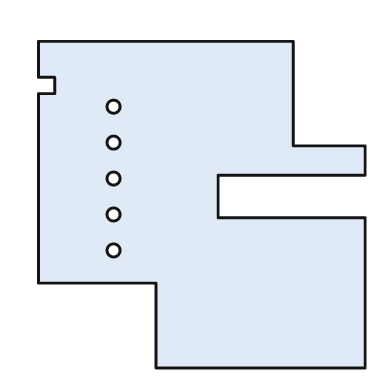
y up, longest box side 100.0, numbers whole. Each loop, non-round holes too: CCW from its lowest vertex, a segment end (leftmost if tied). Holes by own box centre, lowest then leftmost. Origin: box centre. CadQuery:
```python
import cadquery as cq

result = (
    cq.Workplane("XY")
    .moveTo(-14.0, -50.0)
    .lineTo(50.0, -50.0)
    .lineTo(50.0, -4.0)
    .lineTo(5.0, -4.0)
    .lineTo(5.0, 9.0)
    .lineTo(50.0, 9.0)
    .lineTo(50.0, 18.0)
    .lineTo(28.0, 18.0)
    .lineTo(28.0, 50.0)
    .lineTo(-50.0, 50.0)
    .lineTo(-50.0, 39.0)
    .lineTo(-45.0, 39.0)
    .lineTo(-45.0, 34.0)
    .lineTo(-50.0, 34.0)
    .lineTo(-50.0, -24.0)
    .lineTo(-14.0, -24.0)
    .close()
    .moveTo(-27.0, -14.0)
    .circle(2.0)
    .moveTo(-27.0, -3.0)
    .circle(2.0)
    .moveTo(-27.0, 8.0)
    .circle(2.0)
    .moveTo(-27.0, 19.0)
    .circle(2.0)
    .moveTo(-27.0, 30.0)
    .circle(2.0)
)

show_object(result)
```